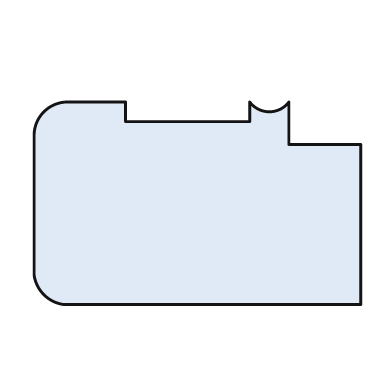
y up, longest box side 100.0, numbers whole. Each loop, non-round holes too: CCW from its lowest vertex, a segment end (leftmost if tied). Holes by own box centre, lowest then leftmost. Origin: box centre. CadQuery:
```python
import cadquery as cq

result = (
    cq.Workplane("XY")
    .moveTo(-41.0, -31.0)
    .lineTo(50.0, -31.0)
    .lineTo(50.0, 18.0)
    .lineTo(28.0, 18.0)
    .lineTo(28.0, 31.0)
    .threePointArc((22.0, 28.0), (16.0, 31.0))
    .lineTo(16.0, 25.0)
    .lineTo(-22.0, 25.0)
    .lineTo(-22.0, 31.0)
    .lineTo(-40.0, 31.0)
    .threePointArc((-47.0, 28.0), (-50.0, 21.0))
    .lineTo(-50.0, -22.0)
    .threePointArc((-47.0, -28.0), (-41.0, -31.0))
    .close()
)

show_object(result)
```